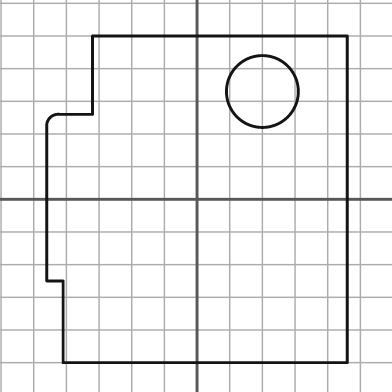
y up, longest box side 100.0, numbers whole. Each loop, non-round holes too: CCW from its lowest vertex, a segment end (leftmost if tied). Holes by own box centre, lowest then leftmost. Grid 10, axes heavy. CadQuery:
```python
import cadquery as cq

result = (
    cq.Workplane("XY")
    .moveTo(-41.0, -50.0)
    .lineTo(46.0, -50.0)
    .lineTo(46.0, 50.0)
    .lineTo(-32.0, 50.0)
    .lineTo(-32.0, 26.0)
    .lineTo(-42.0, 26.0)
    .threePointArc((-45.0, 25.0), (-46.0, 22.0))
    .lineTo(-46.0, -25.0)
    .lineTo(-41.0, -25.0)
    .close()
    .moveTo(20.0, 33.0)
    .circle(11.0)
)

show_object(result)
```